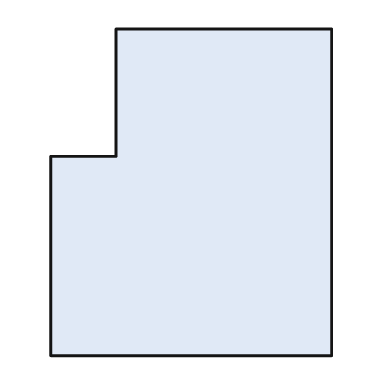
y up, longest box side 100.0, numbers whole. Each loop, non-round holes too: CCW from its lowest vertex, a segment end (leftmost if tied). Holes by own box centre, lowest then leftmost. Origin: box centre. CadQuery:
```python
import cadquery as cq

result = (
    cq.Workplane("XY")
    .moveTo(-43.0, -50.0)
    .lineTo(43.0, -50.0)
    .lineTo(43.0, 50.0)
    .lineTo(-23.0, 50.0)
    .lineTo(-23.0, 11.0)
    .lineTo(-43.0, 11.0)
    .close()
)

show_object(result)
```